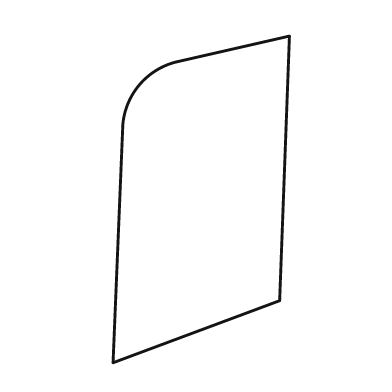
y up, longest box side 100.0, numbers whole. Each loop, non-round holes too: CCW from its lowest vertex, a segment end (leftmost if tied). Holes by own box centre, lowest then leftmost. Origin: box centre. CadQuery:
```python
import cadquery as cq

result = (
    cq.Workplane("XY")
    .moveTo(-27.0, -50.0)
    .lineTo(24.0, -31.0)
    .lineTo(27.0, 50.0)
    .lineTo(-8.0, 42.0)
    .threePointArc((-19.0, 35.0), (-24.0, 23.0))
    .close()
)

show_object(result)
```